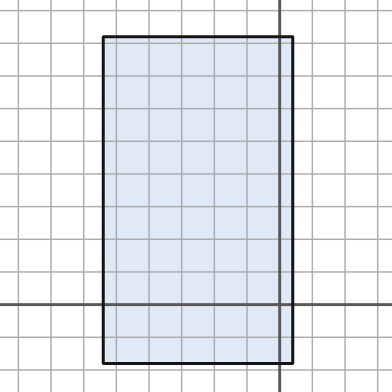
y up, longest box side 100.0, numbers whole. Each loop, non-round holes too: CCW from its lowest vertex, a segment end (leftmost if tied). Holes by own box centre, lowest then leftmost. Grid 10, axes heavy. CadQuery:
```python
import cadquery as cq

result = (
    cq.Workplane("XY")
    .moveTo(-54.0, -18.0)
    .lineTo(4.0, -18.0)
    .lineTo(4.0, 82.0)
    .lineTo(-54.0, 82.0)
    .close()
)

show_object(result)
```